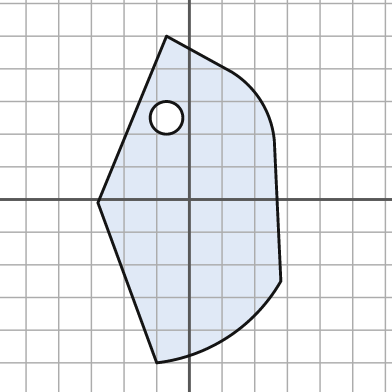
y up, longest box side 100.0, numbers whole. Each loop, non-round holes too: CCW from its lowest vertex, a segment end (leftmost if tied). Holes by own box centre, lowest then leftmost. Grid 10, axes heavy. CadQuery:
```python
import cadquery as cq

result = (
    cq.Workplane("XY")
    .moveTo(-10.0, -50.0)
    .threePointArc((12.0, -42.0), (28.0, -25.0))
    .lineTo(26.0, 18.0)
    .threePointArc((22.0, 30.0), (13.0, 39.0))
    .lineTo(-7.0, 50.0)
    .lineTo(-28.0, -1.0)
    .close()
    .moveTo(-7.0, 25.0)
    .circle(5.0)
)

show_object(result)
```